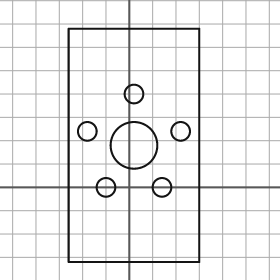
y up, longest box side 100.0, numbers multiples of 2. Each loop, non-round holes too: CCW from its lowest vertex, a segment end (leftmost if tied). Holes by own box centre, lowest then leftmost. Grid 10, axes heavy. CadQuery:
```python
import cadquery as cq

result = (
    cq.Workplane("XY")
    .moveTo(-26.0, -32.0)
    .lineTo(30.0, -32.0)
    .lineTo(30.0, 68.0)
    .lineTo(-26.0, 68.0)
    .close()
    .moveTo(-10.0, 0.0)
    .circle(4.0)
    .moveTo(14.0, 0.0)
    .circle(4.0)
    .moveTo(2.0, 18.0)
    .circle(10.0)
    .moveTo(-18.0, 24.0)
    .circle(4.0)
    .moveTo(22.0, 24.0)
    .circle(4.0)
    .moveTo(2.0, 40.0)
    .circle(4.0)
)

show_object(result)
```